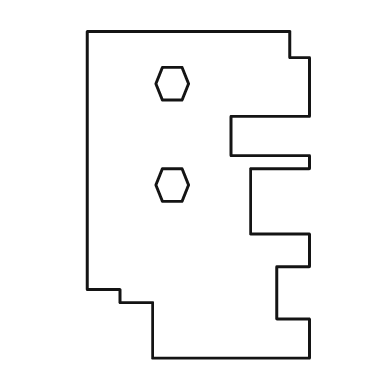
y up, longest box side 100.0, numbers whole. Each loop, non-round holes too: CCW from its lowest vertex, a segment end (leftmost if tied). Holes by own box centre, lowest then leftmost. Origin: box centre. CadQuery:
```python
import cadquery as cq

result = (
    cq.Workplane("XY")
    .moveTo(-14.0, -50.0)
    .lineTo(34.0, -50.0)
    .lineTo(34.0, -38.0)
    .lineTo(24.0, -38.0)
    .lineTo(24.0, -22.0)
    .lineTo(34.0, -22.0)
    .lineTo(34.0, -12.0)
    .lineTo(16.0, -12.0)
    .lineTo(16.0, 8.0)
    .lineTo(34.0, 8.0)
    .lineTo(34.0, 12.0)
    .lineTo(10.0, 12.0)
    .lineTo(10.0, 24.0)
    .lineTo(34.0, 24.0)
    .lineTo(34.0, 42.0)
    .lineTo(28.0, 42.0)
    .lineTo(28.0, 50.0)
    .lineTo(-34.0, 50.0)
    .lineTo(-34.0, -29.0)
    .lineTo(-24.0, -29.0)
    .lineTo(-24.0, -33.0)
    .lineTo(-14.0, -33.0)
    .close()
    .moveTo(-11.0, -2.0)
    .lineTo(-5.0, -2.0)
    .lineTo(-3.0, 3.0)
    .lineTo(-5.0, 8.0)
    .lineTo(-11.0, 8.0)
    .lineTo(-13.0, 3.0)
    .close()
    .moveTo(-11.0, 29.0)
    .lineTo(-5.0, 29.0)
    .lineTo(-3.0, 34.0)
    .lineTo(-5.0, 39.0)
    .lineTo(-11.0, 39.0)
    .lineTo(-13.0, 34.0)
    .close()
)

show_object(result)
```